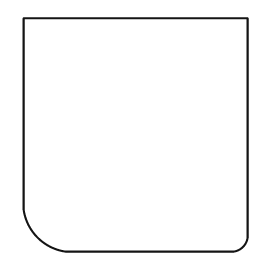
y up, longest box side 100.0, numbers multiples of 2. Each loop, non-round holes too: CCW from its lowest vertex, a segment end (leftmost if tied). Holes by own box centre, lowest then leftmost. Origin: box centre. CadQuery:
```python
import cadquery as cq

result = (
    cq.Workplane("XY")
    .moveTo(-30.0, -50.0)
    .lineTo(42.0, -50.0)
    .threePointArc((46.0, -48.0), (48.0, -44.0))
    .lineTo(48.0, 50.0)
    .lineTo(-48.0, 50.0)
    .lineTo(-48.0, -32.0)
    .threePointArc((-42.0, -44.0), (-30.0, -50.0))
    .close()
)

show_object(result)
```